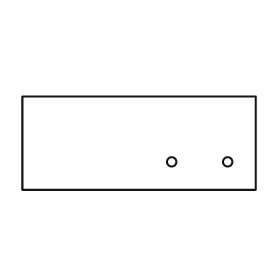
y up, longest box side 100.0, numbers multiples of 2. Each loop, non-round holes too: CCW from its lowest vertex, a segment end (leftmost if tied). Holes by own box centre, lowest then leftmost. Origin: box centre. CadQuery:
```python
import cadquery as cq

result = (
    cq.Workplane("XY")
    .moveTo(-50.0, -20.0)
    .lineTo(50.0, -20.0)
    .lineTo(50.0, 20.0)
    .lineTo(-50.0, 20.0)
    .close()
    .moveTo(14.0, -8.0)
    .circle(2.0)
    .moveTo(38.0, -8.0)
    .circle(2.0)
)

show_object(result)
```